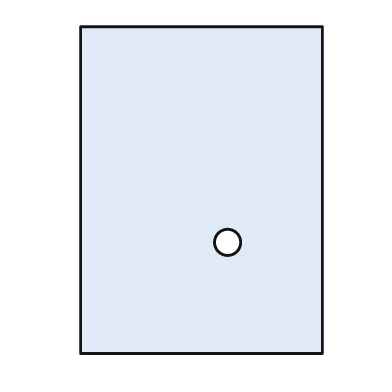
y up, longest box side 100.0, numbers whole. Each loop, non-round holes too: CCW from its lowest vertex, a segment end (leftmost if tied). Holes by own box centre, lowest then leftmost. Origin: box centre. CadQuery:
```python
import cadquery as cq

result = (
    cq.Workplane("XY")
    .moveTo(-37.0, -50.0)
    .lineTo(37.0, -50.0)
    .lineTo(37.0, 50.0)
    .lineTo(-37.0, 50.0)
    .close()
    .moveTo(8.0, -16.0)
    .circle(4.0)
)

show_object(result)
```